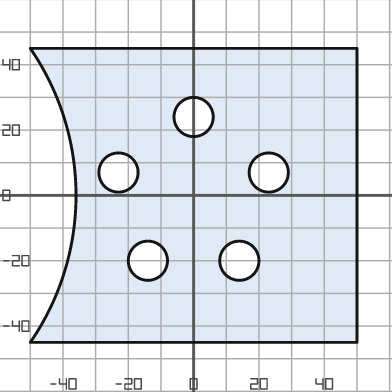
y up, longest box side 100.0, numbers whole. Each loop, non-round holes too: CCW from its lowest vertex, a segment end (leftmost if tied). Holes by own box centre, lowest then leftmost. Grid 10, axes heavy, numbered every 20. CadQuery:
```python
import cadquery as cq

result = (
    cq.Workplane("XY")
    .moveTo(-50.0, -45.0)
    .lineTo(50.0, -45.0)
    .lineTo(50.0, 45.0)
    .lineTo(-50.0, 45.0)
    .threePointArc((-36.0, 0.0), (-50.0, -45.0))
    .close()
    .moveTo(-14.0, -20.0)
    .circle(6.0)
    .moveTo(14.0, -20.0)
    .circle(6.0)
    .moveTo(-23.0, 7.0)
    .circle(6.0)
    .moveTo(23.0, 7.0)
    .circle(6.0)
    .moveTo(0.0, 24.0)
    .circle(6.0)
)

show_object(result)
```